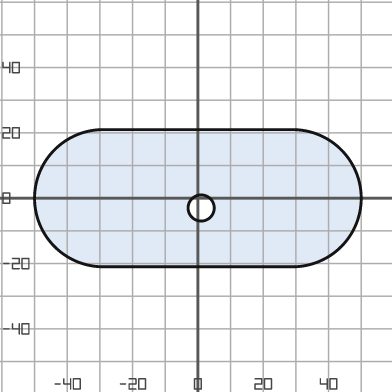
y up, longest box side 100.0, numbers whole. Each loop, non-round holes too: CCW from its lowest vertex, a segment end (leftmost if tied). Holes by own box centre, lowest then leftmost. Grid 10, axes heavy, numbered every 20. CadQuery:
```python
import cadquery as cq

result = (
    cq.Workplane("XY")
    .moveTo(-29.0, -21.0)
    .lineTo(29.0, -21.0)
    .threePointArc((50.0, 0.0), (29.0, 21.0))
    .lineTo(-29.0, 21.0)
    .threePointArc((-50.0, 0.0), (-29.0, -21.0))
    .close()
    .moveTo(1.0, -3.0)
    .circle(4.0)
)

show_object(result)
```